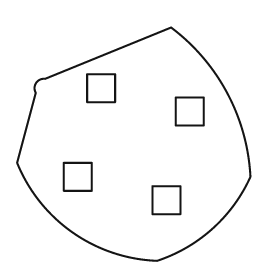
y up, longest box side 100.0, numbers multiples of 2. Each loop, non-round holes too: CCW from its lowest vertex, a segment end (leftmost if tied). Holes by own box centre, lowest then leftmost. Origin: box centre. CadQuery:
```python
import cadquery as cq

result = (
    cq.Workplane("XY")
    .moveTo(10.0, -50.0)
    .threePointArc((34.0, -36.0), (50.0, -14.0))
    .threePointArc((40.0, 22.0), (16.0, 50.0))
    .lineTo(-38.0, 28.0)
    .threePointArc((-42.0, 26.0), (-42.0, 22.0))
    .lineTo(-50.0, -8.0)
    .threePointArc((-26.0, -38.0), (10.0, -50.0))
    .close()
    .moveTo(8.0, -30.0)
    .lineTo(20.0, -30.0)
    .lineTo(20.0, -18.0)
    .lineTo(8.0, -18.0)
    .close()
    .moveTo(-30.0, -20.0)
    .lineTo(-18.0, -20.0)
    .lineTo(-18.0, -8.0)
    .lineTo(-30.0, -8.0)
    .close()
    .moveTo(18.0, 8.0)
    .lineTo(30.0, 8.0)
    .lineTo(30.0, 20.0)
    .lineTo(18.0, 20.0)
    .close()
    .moveTo(-20.0, 18.0)
    .lineTo(-8.0, 18.0)
    .lineTo(-8.0, 30.0)
    .lineTo(-20.0, 30.0)
    .close()
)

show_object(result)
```